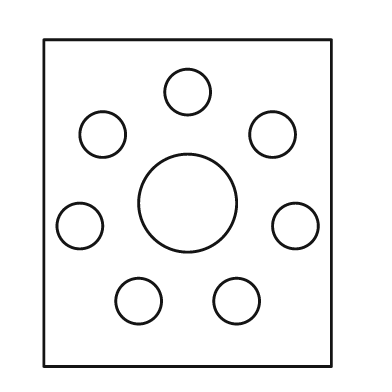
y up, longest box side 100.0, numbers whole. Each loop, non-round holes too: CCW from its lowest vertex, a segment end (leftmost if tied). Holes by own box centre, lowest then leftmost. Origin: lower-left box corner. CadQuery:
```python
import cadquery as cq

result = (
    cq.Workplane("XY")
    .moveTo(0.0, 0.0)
    .lineTo(88.0, 0.0)
    .lineTo(88.0, 100.0)
    .lineTo(0.0, 100.0)
    .close()
    .moveTo(29.0, 20.0)
    .circle(7.0)
    .moveTo(59.0, 20.0)
    .circle(7.0)
    .moveTo(11.0, 43.0)
    .circle(7.0)
    .moveTo(77.0, 43.0)
    .circle(7.0)
    .moveTo(44.0, 50.0)
    .circle(15.0)
    .moveTo(18.0, 71.0)
    .circle(7.0)
    .moveTo(70.0, 71.0)
    .circle(7.0)
    .moveTo(44.0, 84.0)
    .circle(7.0)
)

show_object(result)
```